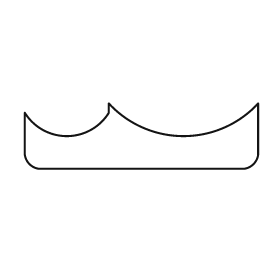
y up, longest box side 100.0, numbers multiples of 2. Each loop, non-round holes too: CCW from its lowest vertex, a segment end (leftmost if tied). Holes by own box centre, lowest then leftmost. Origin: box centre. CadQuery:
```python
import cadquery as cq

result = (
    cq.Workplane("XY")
    .moveTo(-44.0, -14.0)
    .lineTo(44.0, -14.0)
    .threePointArc((48.0, -12.0), (50.0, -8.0))
    .lineTo(50.0, 14.0)
    .threePointArc((18.0, 0.0), (-14.0, 14.0))
    .lineTo(-14.0, 10.0)
    .threePointArc((-32.0, 0.0), (-50.0, 10.0))
    .lineTo(-50.0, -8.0)
    .threePointArc((-48.0, -12.0), (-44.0, -14.0))
    .close()
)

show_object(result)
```